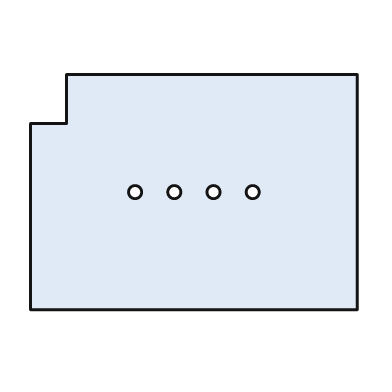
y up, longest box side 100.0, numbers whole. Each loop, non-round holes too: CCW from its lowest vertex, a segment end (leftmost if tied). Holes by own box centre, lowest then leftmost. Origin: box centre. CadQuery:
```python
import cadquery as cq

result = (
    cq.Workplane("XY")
    .moveTo(-50.0, -36.0)
    .lineTo(50.0, -36.0)
    .lineTo(50.0, 36.0)
    .lineTo(-39.0, 36.0)
    .lineTo(-39.0, 21.0)
    .lineTo(-50.0, 21.0)
    .close()
    .moveTo(-18.0, 0.0)
    .circle(2.0)
    .moveTo(-6.0, 0.0)
    .circle(2.0)
    .moveTo(6.0, 0.0)
    .circle(2.0)
    .moveTo(18.0, 0.0)
    .circle(2.0)
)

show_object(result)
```